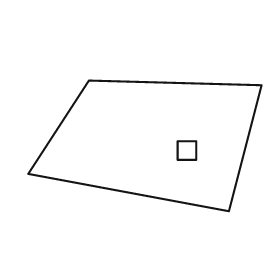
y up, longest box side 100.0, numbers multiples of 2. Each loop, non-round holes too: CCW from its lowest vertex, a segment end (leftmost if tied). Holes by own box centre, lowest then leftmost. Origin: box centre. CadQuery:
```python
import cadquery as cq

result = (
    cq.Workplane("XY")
    .moveTo(36.0, -28.0)
    .lineTo(50.0, 26.0)
    .lineTo(-24.0, 28.0)
    .lineTo(-50.0, -12.0)
    .close()
    .moveTo(14.0, -6.0)
    .lineTo(22.0, -6.0)
    .lineTo(22.0, 2.0)
    .lineTo(14.0, 2.0)
    .close()
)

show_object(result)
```